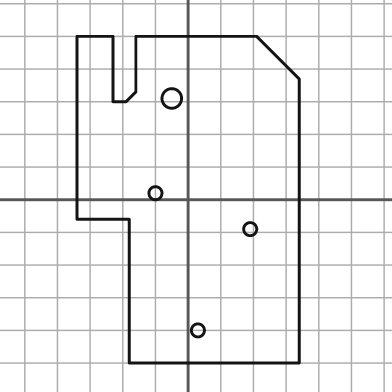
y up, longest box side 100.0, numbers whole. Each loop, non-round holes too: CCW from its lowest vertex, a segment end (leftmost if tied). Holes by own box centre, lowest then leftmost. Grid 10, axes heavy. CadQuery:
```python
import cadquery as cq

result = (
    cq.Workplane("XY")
    .moveTo(-18.0, -50.0)
    .lineTo(34.0, -50.0)
    .lineTo(34.0, 37.0)
    .lineTo(21.0, 50.0)
    .lineTo(-16.0, 50.0)
    .lineTo(-16.0, 33.0)
    .lineTo(-19.0, 30.0)
    .lineTo(-23.0, 30.0)
    .lineTo(-23.0, 50.0)
    .lineTo(-34.0, 50.0)
    .lineTo(-34.0, -6.0)
    .lineTo(-18.0, -6.0)
    .close()
    .moveTo(3.0, -40.0)
    .circle(2.0)
    .moveTo(19.0, -9.0)
    .circle(2.0)
    .moveTo(-10.0, 2.0)
    .circle(2.0)
    .moveTo(-5.0, 31.0)
    .circle(3.0)
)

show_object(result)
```